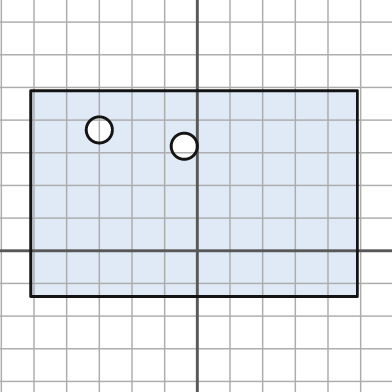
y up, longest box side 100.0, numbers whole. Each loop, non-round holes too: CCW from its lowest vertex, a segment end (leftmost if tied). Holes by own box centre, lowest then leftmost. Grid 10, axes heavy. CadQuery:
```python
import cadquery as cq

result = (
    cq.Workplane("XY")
    .moveTo(-51.0, -14.0)
    .lineTo(49.0, -14.0)
    .lineTo(49.0, 49.0)
    .lineTo(-51.0, 49.0)
    .close()
    .moveTo(-4.0, 32.0)
    .circle(4.0)
    .moveTo(-30.0, 37.0)
    .circle(4.0)
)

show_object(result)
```